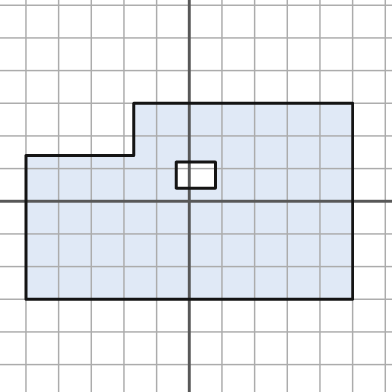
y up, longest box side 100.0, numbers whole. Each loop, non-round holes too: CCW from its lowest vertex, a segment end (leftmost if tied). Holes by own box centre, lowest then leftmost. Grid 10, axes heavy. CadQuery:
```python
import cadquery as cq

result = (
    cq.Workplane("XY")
    .moveTo(-50.0, -30.0)
    .lineTo(50.0, -30.0)
    .lineTo(50.0, 30.0)
    .lineTo(-17.0, 30.0)
    .lineTo(-17.0, 14.0)
    .lineTo(-50.0, 14.0)
    .close()
    .moveTo(-4.0, 4.0)
    .lineTo(8.0, 4.0)
    .lineTo(8.0, 12.0)
    .lineTo(-4.0, 12.0)
    .close()
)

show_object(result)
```